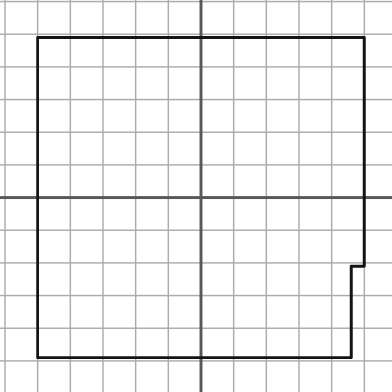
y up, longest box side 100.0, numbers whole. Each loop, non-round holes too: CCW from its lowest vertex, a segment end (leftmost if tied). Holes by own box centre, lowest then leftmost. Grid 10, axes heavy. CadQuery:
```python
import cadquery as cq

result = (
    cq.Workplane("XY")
    .moveTo(-50.0, -49.0)
    .lineTo(46.0, -49.0)
    .lineTo(46.0, -21.0)
    .lineTo(50.0, -21.0)
    .lineTo(50.0, 49.0)
    .lineTo(-50.0, 49.0)
    .close()
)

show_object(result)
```